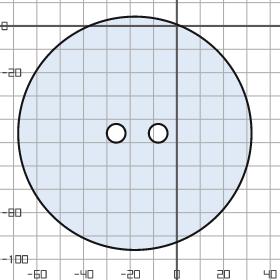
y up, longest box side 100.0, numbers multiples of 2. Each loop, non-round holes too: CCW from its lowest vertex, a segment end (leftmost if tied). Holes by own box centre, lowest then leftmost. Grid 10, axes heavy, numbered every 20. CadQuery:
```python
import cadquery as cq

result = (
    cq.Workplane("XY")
    .moveTo(-18.0, -46.0)
    .circle(50.0)
    .moveTo(-26.0, -46.0)
    .circle(4.0)
    .moveTo(-8.0, -46.0)
    .circle(4.0)
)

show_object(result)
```